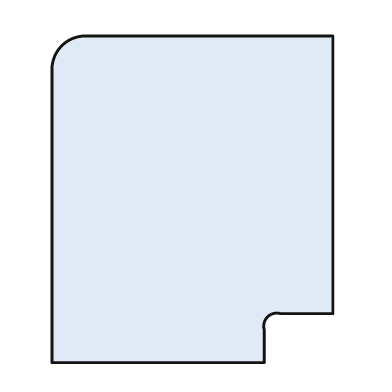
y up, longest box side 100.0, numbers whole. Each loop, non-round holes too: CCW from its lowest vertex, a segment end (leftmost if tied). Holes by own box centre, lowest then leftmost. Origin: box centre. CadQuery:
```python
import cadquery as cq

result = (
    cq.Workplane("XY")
    .moveTo(-43.0, -50.0)
    .lineTo(22.0, -50.0)
    .lineTo(22.0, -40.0)
    .threePointArc((23.0, -36.0), (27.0, -35.0))
    .lineTo(43.0, -35.0)
    .lineTo(43.0, 50.0)
    .lineTo(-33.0, 50.0)
    .threePointArc((-40.0, 47.0), (-43.0, 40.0))
    .close()
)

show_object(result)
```